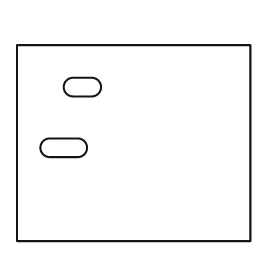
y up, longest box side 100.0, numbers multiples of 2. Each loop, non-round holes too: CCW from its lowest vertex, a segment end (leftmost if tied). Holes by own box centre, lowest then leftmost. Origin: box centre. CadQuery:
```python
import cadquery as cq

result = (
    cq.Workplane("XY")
    .moveTo(-50.0, -42.0)
    .lineTo(50.0, -42.0)
    .lineTo(50.0, 42.0)
    .lineTo(-50.0, 42.0)
    .close()
    .moveTo(-36.0, -6.0)
    .lineTo(-24.0, -6.0)
    .threePointArc((-20.0, -2.0), (-24.0, 2.0))
    .lineTo(-36.0, 2.0)
    .threePointArc((-40.0, -2.0), (-36.0, -6.0))
    .close()
    .moveTo(-26.0, 20.0)
    .lineTo(-18.0, 20.0)
    .threePointArc((-14.0, 24.0), (-18.0, 28.0))
    .lineTo(-26.0, 28.0)
    .threePointArc((-30.0, 24.0), (-26.0, 20.0))
    .close()
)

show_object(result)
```